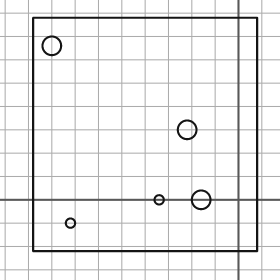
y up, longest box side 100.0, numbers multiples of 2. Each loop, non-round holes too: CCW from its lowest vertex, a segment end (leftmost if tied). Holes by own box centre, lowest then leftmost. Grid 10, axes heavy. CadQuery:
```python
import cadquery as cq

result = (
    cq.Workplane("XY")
    .moveTo(-88.0, -22.0)
    .lineTo(8.0, -22.0)
    .lineTo(8.0, 78.0)
    .lineTo(-88.0, 78.0)
    .close()
    .moveTo(-72.0, -10.0)
    .circle(2.0)
    .moveTo(-34.0, 0.0)
    .circle(2.0)
    .moveTo(-16.0, 0.0)
    .circle(4.0)
    .moveTo(-22.0, 30.0)
    .circle(4.0)
    .moveTo(-80.0, 66.0)
    .circle(4.0)
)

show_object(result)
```